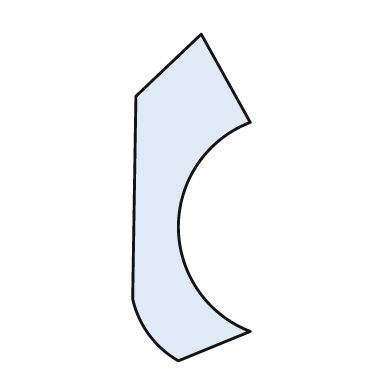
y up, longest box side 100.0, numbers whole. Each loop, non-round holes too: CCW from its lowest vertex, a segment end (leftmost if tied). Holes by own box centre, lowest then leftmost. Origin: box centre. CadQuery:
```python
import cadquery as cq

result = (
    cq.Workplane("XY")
    .moveTo(-4.0, -50.0)
    .lineTo(18.0, -41.0)
    .threePointArc((-4.0, -9.0), (18.0, 23.0))
    .lineTo(3.0, 50.0)
    .lineTo(-17.0, 31.0)
    .lineTo(-18.0, -31.0)
    .threePointArc((-13.0, -42.0), (-4.0, -50.0))
    .close()
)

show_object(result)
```